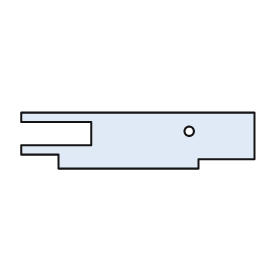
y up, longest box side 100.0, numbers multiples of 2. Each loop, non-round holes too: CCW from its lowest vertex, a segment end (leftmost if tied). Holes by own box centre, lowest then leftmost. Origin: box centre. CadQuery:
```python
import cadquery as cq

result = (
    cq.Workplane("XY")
    .moveTo(-34.0, -12.0)
    .lineTo(26.0, -12.0)
    .lineTo(26.0, -8.0)
    .lineTo(50.0, -8.0)
    .lineTo(50.0, 12.0)
    .lineTo(-50.0, 12.0)
    .lineTo(-50.0, 8.0)
    .lineTo(-20.0, 8.0)
    .lineTo(-20.0, -2.0)
    .lineTo(-50.0, -2.0)
    .lineTo(-50.0, -6.0)
    .lineTo(-34.0, -6.0)
    .close()
    .moveTo(22.0, 4.0)
    .circle(2.0)
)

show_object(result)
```